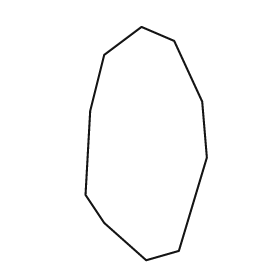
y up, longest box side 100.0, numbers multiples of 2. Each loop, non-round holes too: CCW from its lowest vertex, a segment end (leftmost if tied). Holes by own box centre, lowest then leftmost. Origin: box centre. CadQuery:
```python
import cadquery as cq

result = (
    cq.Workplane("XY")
    .moveTo(0.0, -50.0)
    .lineTo(14.0, -46.0)
    .lineTo(26.0, -6.0)
    .lineTo(24.0, 18.0)
    .lineTo(12.0, 44.0)
    .lineTo(-2.0, 50.0)
    .lineTo(-18.0, 38.0)
    .lineTo(-24.0, 14.0)
    .lineTo(-26.0, -22.0)
    .lineTo(-18.0, -34.0)
    .close()
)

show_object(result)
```